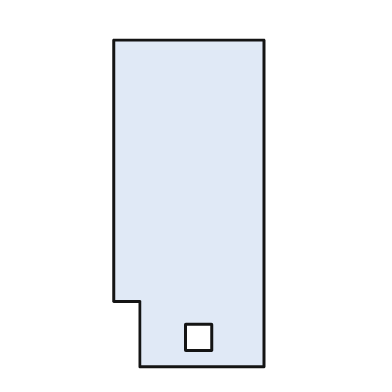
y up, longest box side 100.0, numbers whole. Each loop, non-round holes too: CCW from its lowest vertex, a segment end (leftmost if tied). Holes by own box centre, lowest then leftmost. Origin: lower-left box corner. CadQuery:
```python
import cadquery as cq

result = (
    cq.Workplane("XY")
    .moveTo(8.0, 0.0)
    .lineTo(46.0, 0.0)
    .lineTo(46.0, 100.0)
    .lineTo(0.0, 100.0)
    .lineTo(0.0, 20.0)
    .lineTo(8.0, 20.0)
    .close()
    .moveTo(22.0, 5.0)
    .lineTo(30.0, 5.0)
    .lineTo(30.0, 13.0)
    .lineTo(22.0, 13.0)
    .close()
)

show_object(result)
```